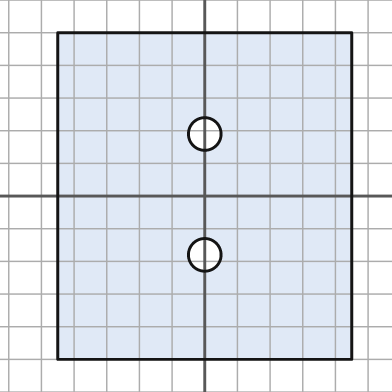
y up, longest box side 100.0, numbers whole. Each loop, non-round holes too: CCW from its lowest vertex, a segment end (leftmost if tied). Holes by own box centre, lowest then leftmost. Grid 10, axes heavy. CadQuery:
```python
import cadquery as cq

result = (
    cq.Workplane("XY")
    .moveTo(-45.0, -50.0)
    .lineTo(45.0, -50.0)
    .lineTo(45.0, 50.0)
    .lineTo(-45.0, 50.0)
    .close()
    .moveTo(0.0, -18.0)
    .circle(5.0)
    .moveTo(0.0, 19.0)
    .circle(5.0)
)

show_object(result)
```